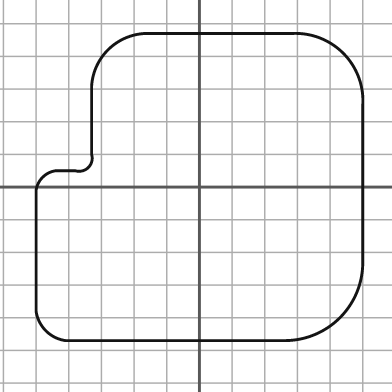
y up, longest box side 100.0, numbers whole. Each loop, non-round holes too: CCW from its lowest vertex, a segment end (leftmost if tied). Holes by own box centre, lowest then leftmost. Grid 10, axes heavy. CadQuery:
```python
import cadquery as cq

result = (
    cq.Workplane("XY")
    .moveTo(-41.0, -47.0)
    .lineTo(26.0, -47.0)
    .threePointArc((43.0, -40.0), (50.0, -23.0))
    .lineTo(50.0, 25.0)
    .threePointArc((44.0, 41.0), (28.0, 47.0))
    .lineTo(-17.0, 47.0)
    .threePointArc((-28.0, 42.0), (-33.0, 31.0))
    .lineTo(-33.0, 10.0)
    .threePointArc((-34.0, 6.0), (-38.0, 5.0))
    .lineTo(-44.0, 5.0)
    .threePointArc((-48.0, 3.0), (-50.0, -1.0))
    .lineTo(-50.0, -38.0)
    .threePointArc((-47.0, -44.0), (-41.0, -47.0))
    .close()
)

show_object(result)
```